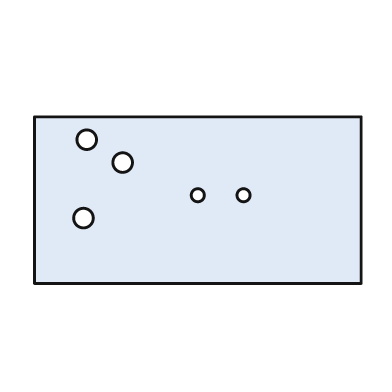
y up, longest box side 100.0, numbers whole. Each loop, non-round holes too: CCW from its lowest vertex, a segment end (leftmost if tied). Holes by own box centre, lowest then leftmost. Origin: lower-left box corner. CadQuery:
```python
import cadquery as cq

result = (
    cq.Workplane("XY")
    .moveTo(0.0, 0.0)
    .lineTo(100.0, 0.0)
    .lineTo(100.0, 51.0)
    .lineTo(0.0, 51.0)
    .close()
    .moveTo(15.0, 20.0)
    .circle(3.0)
    .moveTo(50.0, 27.0)
    .circle(2.0)
    .moveTo(64.0, 27.0)
    .circle(2.0)
    .moveTo(27.0, 37.0)
    .circle(3.0)
    .moveTo(16.0, 44.0)
    .circle(3.0)
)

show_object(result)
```